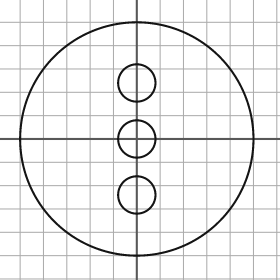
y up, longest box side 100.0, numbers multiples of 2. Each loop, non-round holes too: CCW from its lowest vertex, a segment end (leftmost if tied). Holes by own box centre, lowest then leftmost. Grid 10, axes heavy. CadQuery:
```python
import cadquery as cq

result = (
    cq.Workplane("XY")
    .moveTo(0.0, 0.0)
    .circle(50.0)
    .moveTo(0.0, -24.0)
    .circle(8.0)
    .moveTo(0.0, 0.0)
    .circle(8.0)
    .moveTo(0.0, 24.0)
    .circle(8.0)
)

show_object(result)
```